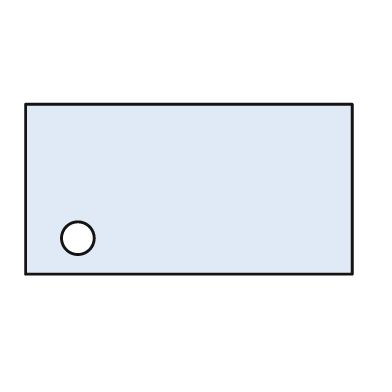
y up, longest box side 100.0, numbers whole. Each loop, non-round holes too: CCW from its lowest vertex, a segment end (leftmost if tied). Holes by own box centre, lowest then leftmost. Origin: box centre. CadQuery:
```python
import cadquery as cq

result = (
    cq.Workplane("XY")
    .moveTo(-50.0, -26.0)
    .lineTo(50.0, -26.0)
    .lineTo(50.0, 26.0)
    .lineTo(-50.0, 26.0)
    .close()
    .moveTo(-34.0, -15.0)
    .circle(5.0)
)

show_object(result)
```